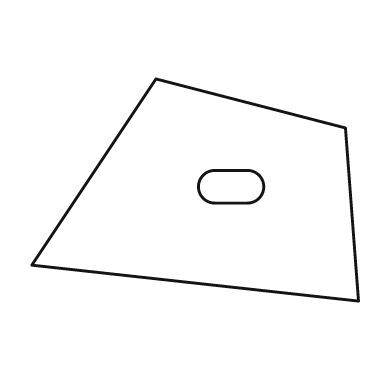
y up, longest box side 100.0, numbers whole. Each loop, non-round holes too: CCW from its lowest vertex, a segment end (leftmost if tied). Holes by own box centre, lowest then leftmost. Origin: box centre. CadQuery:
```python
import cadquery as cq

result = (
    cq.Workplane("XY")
    .moveTo(50.0, -34.0)
    .lineTo(46.0, 19.0)
    .lineTo(-12.0, 34.0)
    .lineTo(-50.0, -23.0)
    .close()
    .moveTo(6.0, -4.0)
    .lineTo(16.0, -4.0)
    .threePointArc((21.0, 1.0), (16.0, 6.0))
    .lineTo(6.0, 6.0)
    .threePointArc((1.0, 1.0), (6.0, -4.0))
    .close()
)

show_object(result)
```